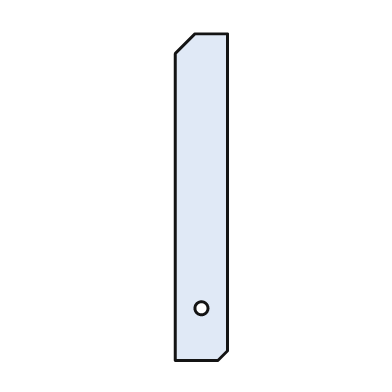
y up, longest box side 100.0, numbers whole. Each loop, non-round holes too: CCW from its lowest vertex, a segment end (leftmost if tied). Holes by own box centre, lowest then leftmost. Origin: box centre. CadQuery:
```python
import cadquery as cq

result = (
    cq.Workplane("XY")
    .moveTo(-8.0, -50.0)
    .lineTo(5.0, -50.0)
    .lineTo(8.0, -47.0)
    .lineTo(8.0, 50.0)
    .lineTo(-2.0, 50.0)
    .lineTo(-8.0, 44.0)
    .close()
    .moveTo(0.0, -34.0)
    .circle(2.0)
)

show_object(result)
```